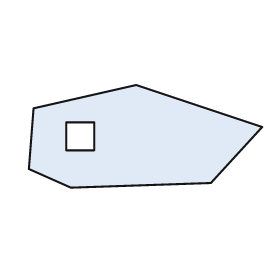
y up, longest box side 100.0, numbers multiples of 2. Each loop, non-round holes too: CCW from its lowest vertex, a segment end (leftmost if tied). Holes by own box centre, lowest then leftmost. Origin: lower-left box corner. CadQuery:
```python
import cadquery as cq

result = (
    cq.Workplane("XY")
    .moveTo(18.0, 0.0)
    .lineTo(78.0, 2.0)
    .lineTo(100.0, 26.0)
    .lineTo(46.0, 44.0)
    .lineTo(2.0, 34.0)
    .lineTo(0.0, 8.0)
    .close()
    .moveTo(16.0, 16.0)
    .lineTo(28.0, 16.0)
    .lineTo(28.0, 28.0)
    .lineTo(16.0, 28.0)
    .close()
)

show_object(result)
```